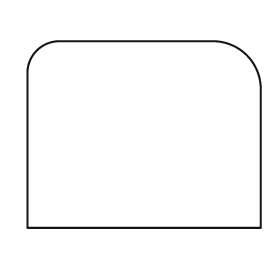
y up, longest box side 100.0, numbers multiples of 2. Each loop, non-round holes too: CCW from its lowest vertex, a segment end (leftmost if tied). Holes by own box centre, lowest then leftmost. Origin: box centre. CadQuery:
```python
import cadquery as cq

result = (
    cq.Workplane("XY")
    .moveTo(-50.0, -40.0)
    .lineTo(50.0, -40.0)
    .lineTo(50.0, 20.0)
    .threePointArc((44.0, 34.0), (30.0, 40.0))
    .lineTo(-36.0, 40.0)
    .threePointArc((-46.0, 36.0), (-50.0, 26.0))
    .close()
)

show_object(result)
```